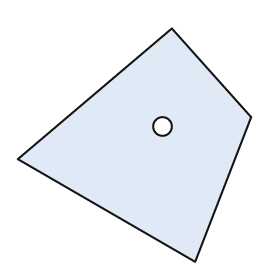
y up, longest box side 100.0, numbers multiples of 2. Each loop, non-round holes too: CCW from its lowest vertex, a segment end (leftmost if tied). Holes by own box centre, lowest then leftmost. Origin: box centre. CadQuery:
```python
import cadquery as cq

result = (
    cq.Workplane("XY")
    .moveTo(26.0, -50.0)
    .lineTo(50.0, 12.0)
    .lineTo(16.0, 50.0)
    .lineTo(-50.0, -6.0)
    .close()
    .moveTo(12.0, 8.0)
    .circle(4.0)
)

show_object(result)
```